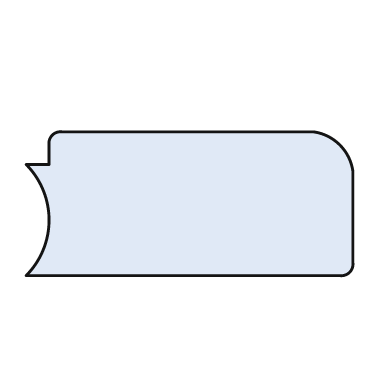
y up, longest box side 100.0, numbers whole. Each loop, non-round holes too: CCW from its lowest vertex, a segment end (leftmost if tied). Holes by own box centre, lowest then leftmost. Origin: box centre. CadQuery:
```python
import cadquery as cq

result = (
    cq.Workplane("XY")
    .moveTo(-50.0, -22.0)
    .lineTo(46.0, -22.0)
    .threePointArc((49.0, -21.0), (50.0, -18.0))
    .lineTo(50.0, 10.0)
    .threePointArc((46.0, 18.0), (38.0, 22.0))
    .lineTo(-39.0, 22.0)
    .threePointArc((-42.0, 21.0), (-43.0, 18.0))
    .lineTo(-43.0, 12.0)
    .lineTo(-50.0, 12.0)
    .threePointArc((-43.0, -5.0), (-50.0, -22.0))
    .close()
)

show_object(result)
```